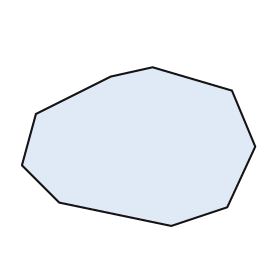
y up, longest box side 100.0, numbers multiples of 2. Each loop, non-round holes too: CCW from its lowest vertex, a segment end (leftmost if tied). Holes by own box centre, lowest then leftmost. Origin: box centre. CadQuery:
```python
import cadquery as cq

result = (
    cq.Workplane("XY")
    .moveTo(14.0, -34.0)
    .lineTo(38.0, -26.0)
    .lineTo(50.0, 0.0)
    .lineTo(40.0, 24.0)
    .lineTo(6.0, 34.0)
    .lineTo(-12.0, 30.0)
    .lineTo(-44.0, 14.0)
    .lineTo(-50.0, -8.0)
    .lineTo(-34.0, -24.0)
    .close()
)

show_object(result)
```